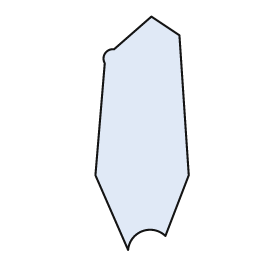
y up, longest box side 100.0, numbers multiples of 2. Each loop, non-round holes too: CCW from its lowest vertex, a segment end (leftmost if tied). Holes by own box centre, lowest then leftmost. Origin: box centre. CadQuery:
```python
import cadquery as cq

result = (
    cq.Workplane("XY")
    .moveTo(-6.0, -50.0)
    .threePointArc((0.0, -42.0), (10.0, -44.0))
    .lineTo(20.0, -18.0)
    .lineTo(16.0, 42.0)
    .lineTo(4.0, 50.0)
    .lineTo(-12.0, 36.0)
    .threePointArc((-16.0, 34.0), (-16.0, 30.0))
    .lineTo(-20.0, -18.0)
    .close()
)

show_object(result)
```